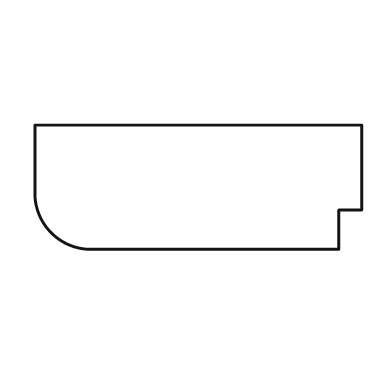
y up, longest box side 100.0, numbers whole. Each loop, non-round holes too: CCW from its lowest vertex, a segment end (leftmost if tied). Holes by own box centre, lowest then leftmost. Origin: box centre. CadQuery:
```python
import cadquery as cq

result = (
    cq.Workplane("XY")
    .moveTo(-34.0, -19.0)
    .lineTo(43.0, -19.0)
    .lineTo(43.0, -7.0)
    .lineTo(50.0, -7.0)
    .lineTo(50.0, 19.0)
    .lineTo(-50.0, 19.0)
    .lineTo(-50.0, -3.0)
    .threePointArc((-45.0, -14.0), (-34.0, -19.0))
    .close()
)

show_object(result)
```